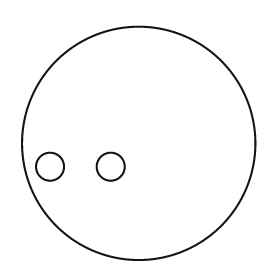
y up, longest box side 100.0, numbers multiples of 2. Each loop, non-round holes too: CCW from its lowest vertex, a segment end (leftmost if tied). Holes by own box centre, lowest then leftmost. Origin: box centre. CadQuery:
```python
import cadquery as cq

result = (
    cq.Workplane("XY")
    .moveTo(0.0, 0.0)
    .circle(50.0)
    .moveTo(-38.0, -10.0)
    .circle(6.0)
    .moveTo(-12.0, -10.0)
    .circle(6.0)
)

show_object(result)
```